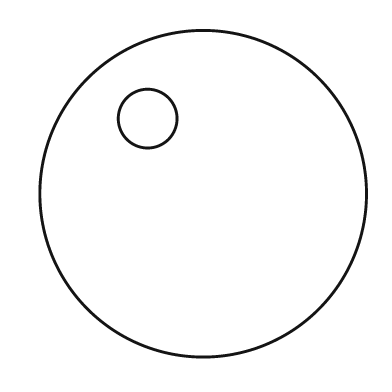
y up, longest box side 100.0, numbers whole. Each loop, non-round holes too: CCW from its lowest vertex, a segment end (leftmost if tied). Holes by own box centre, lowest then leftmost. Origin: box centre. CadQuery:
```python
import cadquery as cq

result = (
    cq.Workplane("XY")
    .moveTo(0.0, 0.0)
    .circle(50.0)
    .moveTo(-17.0, 23.0)
    .circle(9.0)
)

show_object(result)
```